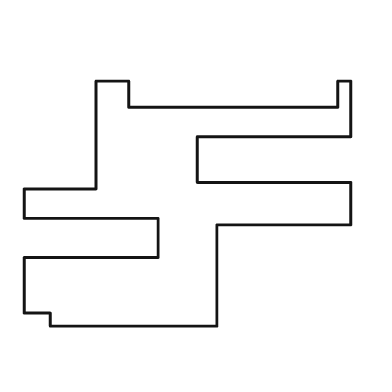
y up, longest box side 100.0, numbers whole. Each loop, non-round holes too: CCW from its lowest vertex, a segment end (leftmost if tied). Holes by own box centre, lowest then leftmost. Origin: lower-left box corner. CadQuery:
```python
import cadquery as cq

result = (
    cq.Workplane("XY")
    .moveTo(8.0, 0.0)
    .lineTo(59.0, 0.0)
    .lineTo(59.0, 31.0)
    .lineTo(100.0, 31.0)
    .lineTo(100.0, 44.0)
    .lineTo(53.0, 44.0)
    .lineTo(53.0, 58.0)
    .lineTo(100.0, 58.0)
    .lineTo(100.0, 75.0)
    .lineTo(96.0, 75.0)
    .lineTo(96.0, 67.0)
    .lineTo(32.0, 67.0)
    .lineTo(32.0, 75.0)
    .lineTo(22.0, 75.0)
    .lineTo(22.0, 42.0)
    .lineTo(0.0, 42.0)
    .lineTo(0.0, 33.0)
    .lineTo(41.0, 33.0)
    .lineTo(41.0, 21.0)
    .lineTo(0.0, 21.0)
    .lineTo(0.0, 4.0)
    .lineTo(8.0, 4.0)
    .close()
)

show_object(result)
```